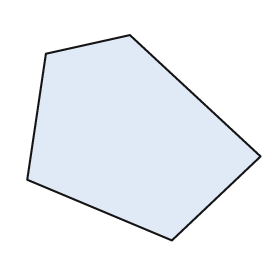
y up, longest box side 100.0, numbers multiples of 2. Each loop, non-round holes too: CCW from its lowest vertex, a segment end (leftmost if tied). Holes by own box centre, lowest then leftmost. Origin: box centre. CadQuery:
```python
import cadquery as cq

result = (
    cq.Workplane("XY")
    .moveTo(12.0, -44.0)
    .lineTo(50.0, -8.0)
    .lineTo(-6.0, 44.0)
    .lineTo(-42.0, 36.0)
    .lineTo(-50.0, -18.0)
    .close()
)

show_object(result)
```